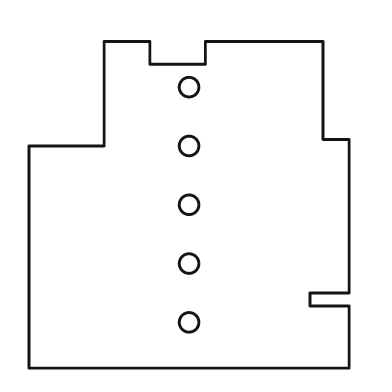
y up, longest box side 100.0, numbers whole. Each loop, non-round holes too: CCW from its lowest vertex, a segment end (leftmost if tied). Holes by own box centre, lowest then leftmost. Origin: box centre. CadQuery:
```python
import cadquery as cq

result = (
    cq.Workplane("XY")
    .moveTo(-49.0, -50.0)
    .lineTo(49.0, -50.0)
    .lineTo(49.0, -31.0)
    .lineTo(37.0, -31.0)
    .lineTo(37.0, -27.0)
    .lineTo(49.0, -27.0)
    .lineTo(49.0, 20.0)
    .lineTo(41.0, 20.0)
    .lineTo(41.0, 50.0)
    .lineTo(5.0, 50.0)
    .lineTo(5.0, 43.0)
    .lineTo(-12.0, 43.0)
    .lineTo(-12.0, 50.0)
    .lineTo(-26.0, 50.0)
    .lineTo(-26.0, 18.0)
    .lineTo(-49.0, 18.0)
    .close()
    .moveTo(0.0, -36.0)
    .circle(3.0)
    .moveTo(0.0, -18.0)
    .circle(3.0)
    .moveTo(0.0, 0.0)
    .circle(3.0)
    .moveTo(0.0, 18.0)
    .circle(3.0)
    .moveTo(0.0, 36.0)
    .circle(3.0)
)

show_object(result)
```